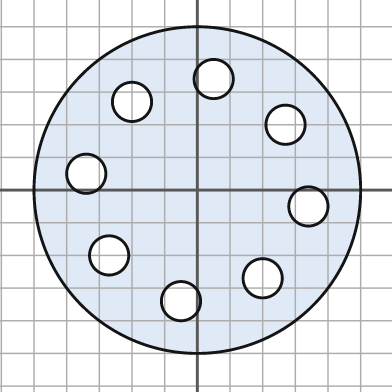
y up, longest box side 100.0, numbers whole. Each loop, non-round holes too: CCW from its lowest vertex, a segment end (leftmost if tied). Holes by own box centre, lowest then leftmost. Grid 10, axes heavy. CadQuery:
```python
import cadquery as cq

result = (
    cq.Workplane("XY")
    .moveTo(0.0, 0.0)
    .circle(50.0)
    .moveTo(-5.0, -34.0)
    .circle(6.0)
    .moveTo(20.0, -27.0)
    .circle(6.0)
    .moveTo(-27.0, -20.0)
    .circle(6.0)
    .moveTo(34.0, -5.0)
    .circle(6.0)
    .moveTo(-34.0, 5.0)
    .circle(6.0)
    .moveTo(27.0, 20.0)
    .circle(6.0)
    .moveTo(-20.0, 27.0)
    .circle(6.0)
    .moveTo(5.0, 34.0)
    .circle(6.0)
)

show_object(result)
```